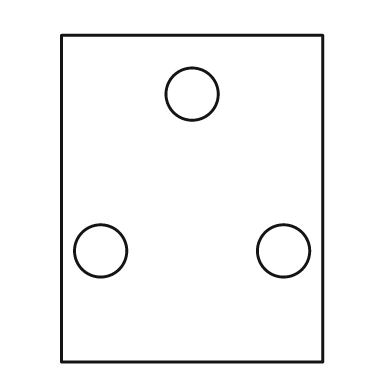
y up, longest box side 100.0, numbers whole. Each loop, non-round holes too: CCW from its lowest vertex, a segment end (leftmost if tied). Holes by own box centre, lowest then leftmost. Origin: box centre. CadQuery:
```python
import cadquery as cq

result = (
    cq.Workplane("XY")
    .moveTo(-40.0, -50.0)
    .lineTo(40.0, -50.0)
    .lineTo(40.0, 50.0)
    .lineTo(-40.0, 50.0)
    .close()
    .moveTo(-28.0, -16.0)
    .circle(8.0)
    .moveTo(28.0, -16.0)
    .circle(8.0)
    .moveTo(0.0, 32.0)
    .circle(8.0)
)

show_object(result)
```